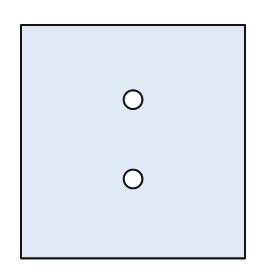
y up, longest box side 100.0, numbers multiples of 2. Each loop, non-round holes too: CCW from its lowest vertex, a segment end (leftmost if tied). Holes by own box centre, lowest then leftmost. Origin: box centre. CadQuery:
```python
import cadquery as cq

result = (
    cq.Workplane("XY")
    .moveTo(-48.0, -50.0)
    .lineTo(48.0, -50.0)
    .lineTo(48.0, 50.0)
    .lineTo(-48.0, 50.0)
    .close()
    .moveTo(0.0, -16.0)
    .circle(4.0)
    .moveTo(0.0, 18.0)
    .circle(4.0)
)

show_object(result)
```